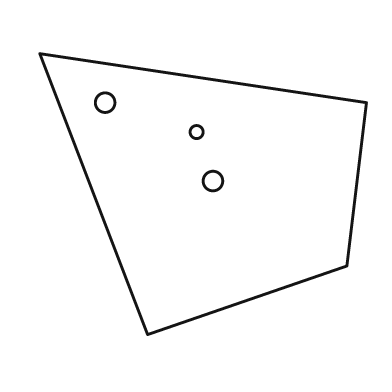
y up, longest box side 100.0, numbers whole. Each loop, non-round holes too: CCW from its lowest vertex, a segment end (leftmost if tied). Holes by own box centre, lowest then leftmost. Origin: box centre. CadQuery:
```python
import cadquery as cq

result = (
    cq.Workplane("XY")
    .moveTo(-17.0, -43.0)
    .lineTo(44.0, -22.0)
    .lineTo(50.0, 28.0)
    .lineTo(-50.0, 43.0)
    .close()
    .moveTo(3.0, 4.0)
    .circle(3.0)
    .moveTo(-2.0, 19.0)
    .circle(2.0)
    .moveTo(-30.0, 28.0)
    .circle(3.0)
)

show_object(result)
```